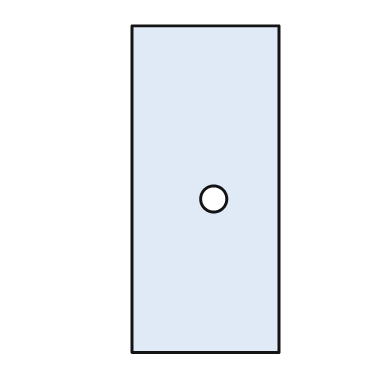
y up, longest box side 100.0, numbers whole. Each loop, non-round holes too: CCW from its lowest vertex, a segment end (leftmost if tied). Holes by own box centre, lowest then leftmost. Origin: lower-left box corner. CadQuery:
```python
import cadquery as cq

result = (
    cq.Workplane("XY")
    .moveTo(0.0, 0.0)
    .lineTo(45.0, 0.0)
    .lineTo(45.0, 100.0)
    .lineTo(0.0, 100.0)
    .close()
    .moveTo(25.0, 47.0)
    .circle(4.0)
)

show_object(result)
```